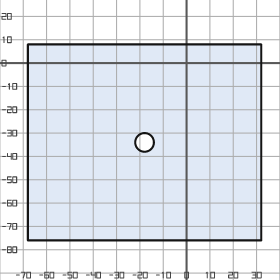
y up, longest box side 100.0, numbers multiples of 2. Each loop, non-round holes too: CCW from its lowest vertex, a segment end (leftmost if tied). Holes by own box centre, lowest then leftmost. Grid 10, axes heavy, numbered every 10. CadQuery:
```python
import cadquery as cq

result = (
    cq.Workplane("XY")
    .moveTo(-68.0, -76.0)
    .lineTo(32.0, -76.0)
    .lineTo(32.0, 8.0)
    .lineTo(-68.0, 8.0)
    .close()
    .moveTo(-18.0, -34.0)
    .circle(4.0)
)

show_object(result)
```